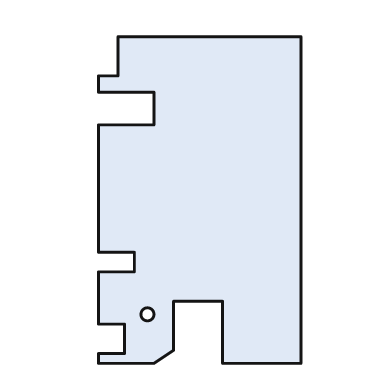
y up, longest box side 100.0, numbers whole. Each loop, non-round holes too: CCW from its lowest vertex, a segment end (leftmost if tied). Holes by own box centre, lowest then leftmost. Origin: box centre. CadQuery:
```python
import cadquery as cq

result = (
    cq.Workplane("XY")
    .moveTo(-31.0, -50.0)
    .lineTo(-14.0, -50.0)
    .lineTo(-8.0, -46.0)
    .lineTo(-8.0, -31.0)
    .lineTo(7.0, -31.0)
    .lineTo(7.0, -50.0)
    .lineTo(31.0, -50.0)
    .lineTo(31.0, 50.0)
    .lineTo(-25.0, 50.0)
    .lineTo(-25.0, 38.0)
    .lineTo(-31.0, 38.0)
    .lineTo(-31.0, 33.0)
    .lineTo(-14.0, 33.0)
    .lineTo(-14.0, 23.0)
    .lineTo(-31.0, 23.0)
    .lineTo(-31.0, -16.0)
    .lineTo(-20.0, -16.0)
    .lineTo(-20.0, -22.0)
    .lineTo(-31.0, -22.0)
    .lineTo(-31.0, -38.0)
    .lineTo(-23.0, -38.0)
    .lineTo(-23.0, -47.0)
    .lineTo(-31.0, -47.0)
    .close()
    .moveTo(-16.0, -35.0)
    .circle(2.0)
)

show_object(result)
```